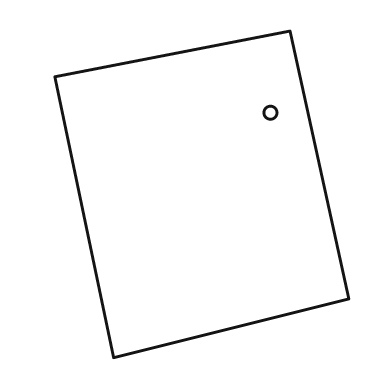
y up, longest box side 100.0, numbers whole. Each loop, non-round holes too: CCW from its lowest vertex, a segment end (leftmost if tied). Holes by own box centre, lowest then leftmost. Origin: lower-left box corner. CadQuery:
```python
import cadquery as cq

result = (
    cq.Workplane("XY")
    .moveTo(18.0, 0.0)
    .lineTo(90.0, 18.0)
    .lineTo(72.0, 100.0)
    .lineTo(0.0, 86.0)
    .close()
    .moveTo(66.0, 75.0)
    .circle(2.0)
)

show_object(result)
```